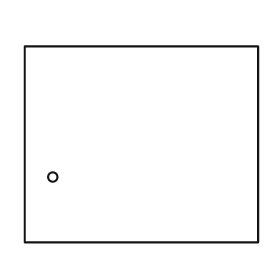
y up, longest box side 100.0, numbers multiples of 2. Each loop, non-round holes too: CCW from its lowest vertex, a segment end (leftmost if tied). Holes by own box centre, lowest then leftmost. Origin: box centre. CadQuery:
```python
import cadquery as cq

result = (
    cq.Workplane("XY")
    .moveTo(-50.0, -42.0)
    .lineTo(50.0, -42.0)
    .lineTo(50.0, 42.0)
    .lineTo(-50.0, 42.0)
    .close()
    .moveTo(-38.0, -14.0)
    .circle(2.0)
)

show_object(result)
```